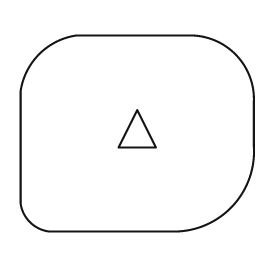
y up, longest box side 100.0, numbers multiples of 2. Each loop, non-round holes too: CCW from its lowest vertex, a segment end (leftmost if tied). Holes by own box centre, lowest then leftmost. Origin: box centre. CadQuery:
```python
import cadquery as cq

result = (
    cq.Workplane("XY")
    .moveTo(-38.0, -42.0)
    .lineTo(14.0, -42.0)
    .threePointArc((40.0, -32.0), (50.0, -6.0))
    .lineTo(50.0, 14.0)
    .threePointArc((42.0, 34.0), (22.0, 42.0))
    .lineTo(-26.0, 42.0)
    .threePointArc((-42.0, 34.0), (-50.0, 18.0))
    .lineTo(-50.0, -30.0)
    .threePointArc((-46.0, -38.0), (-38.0, -42.0))
    .close()
    .moveTo(-8.0, -6.0)
    .lineTo(8.0, -6.0)
    .lineTo(0.0, 10.0)
    .close()
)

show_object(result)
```